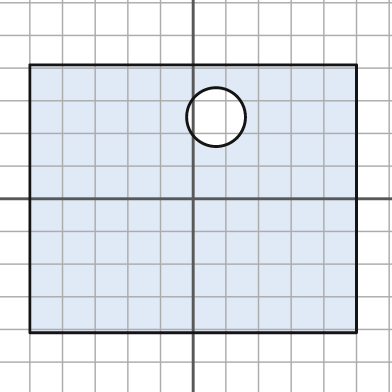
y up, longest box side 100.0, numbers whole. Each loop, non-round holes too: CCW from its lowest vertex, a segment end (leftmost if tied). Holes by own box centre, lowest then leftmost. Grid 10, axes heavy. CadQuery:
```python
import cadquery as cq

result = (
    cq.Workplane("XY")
    .moveTo(-50.0, -41.0)
    .lineTo(50.0, -41.0)
    .lineTo(50.0, 41.0)
    .lineTo(-50.0, 41.0)
    .close()
    .moveTo(7.0, 25.0)
    .circle(9.0)
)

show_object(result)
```